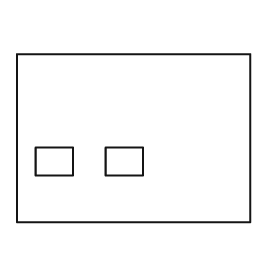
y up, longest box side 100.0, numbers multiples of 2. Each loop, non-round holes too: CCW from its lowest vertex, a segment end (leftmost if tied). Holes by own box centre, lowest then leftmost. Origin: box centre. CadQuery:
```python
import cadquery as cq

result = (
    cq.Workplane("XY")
    .moveTo(-50.0, -36.0)
    .lineTo(50.0, -36.0)
    .lineTo(50.0, 36.0)
    .lineTo(-50.0, 36.0)
    .close()
    .moveTo(-42.0, -16.0)
    .lineTo(-26.0, -16.0)
    .lineTo(-26.0, -4.0)
    .lineTo(-42.0, -4.0)
    .close()
    .moveTo(-12.0, -16.0)
    .lineTo(4.0, -16.0)
    .lineTo(4.0, -4.0)
    .lineTo(-12.0, -4.0)
    .close()
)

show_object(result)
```